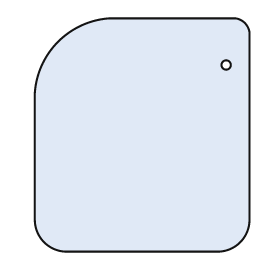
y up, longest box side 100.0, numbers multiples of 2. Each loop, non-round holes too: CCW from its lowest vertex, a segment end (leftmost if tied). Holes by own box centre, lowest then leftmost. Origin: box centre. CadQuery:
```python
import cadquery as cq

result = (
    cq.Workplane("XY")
    .moveTo(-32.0, -50.0)
    .lineTo(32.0, -50.0)
    .threePointArc((42.0, -46.0), (46.0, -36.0))
    .lineTo(46.0, 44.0)
    .threePointArc((44.0, 48.0), (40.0, 50.0))
    .lineTo(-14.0, 50.0)
    .threePointArc((-36.0, 40.0), (-46.0, 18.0))
    .lineTo(-46.0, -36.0)
    .threePointArc((-42.0, -46.0), (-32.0, -50.0))
    .close()
    .moveTo(36.0, 30.0)
    .circle(2.0)
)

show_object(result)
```